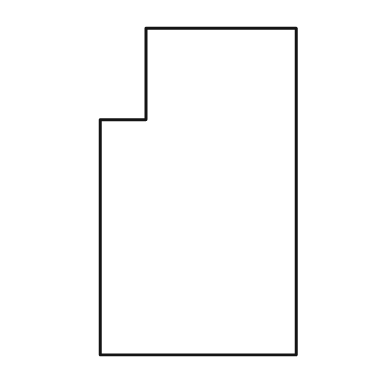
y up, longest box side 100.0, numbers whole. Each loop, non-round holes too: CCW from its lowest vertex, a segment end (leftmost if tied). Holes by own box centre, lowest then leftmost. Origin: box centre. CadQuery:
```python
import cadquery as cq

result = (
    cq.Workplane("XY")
    .moveTo(-30.0, -50.0)
    .lineTo(30.0, -50.0)
    .lineTo(30.0, 50.0)
    .lineTo(-16.0, 50.0)
    .lineTo(-16.0, 22.0)
    .lineTo(-30.0, 22.0)
    .close()
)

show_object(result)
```